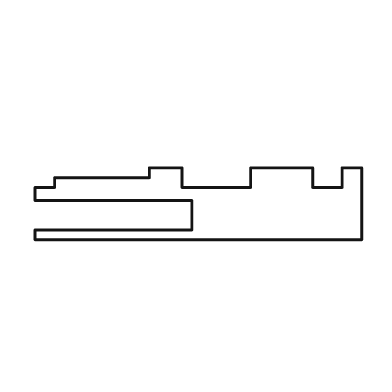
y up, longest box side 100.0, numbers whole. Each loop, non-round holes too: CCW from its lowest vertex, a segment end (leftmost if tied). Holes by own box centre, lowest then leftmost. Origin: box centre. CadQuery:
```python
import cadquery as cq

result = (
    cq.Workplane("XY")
    .moveTo(-50.0, -11.0)
    .lineTo(50.0, -11.0)
    .lineTo(50.0, 11.0)
    .lineTo(44.0, 11.0)
    .lineTo(44.0, 5.0)
    .lineTo(35.0, 5.0)
    .lineTo(35.0, 11.0)
    .lineTo(16.0, 11.0)
    .lineTo(16.0, 5.0)
    .lineTo(-5.0, 5.0)
    .lineTo(-5.0, 11.0)
    .lineTo(-15.0, 11.0)
    .lineTo(-15.0, 8.0)
    .lineTo(-44.0, 8.0)
    .lineTo(-44.0, 5.0)
    .lineTo(-50.0, 5.0)
    .lineTo(-50.0, 1.0)
    .lineTo(-2.0, 1.0)
    .lineTo(-2.0, -8.0)
    .lineTo(-50.0, -8.0)
    .close()
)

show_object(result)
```